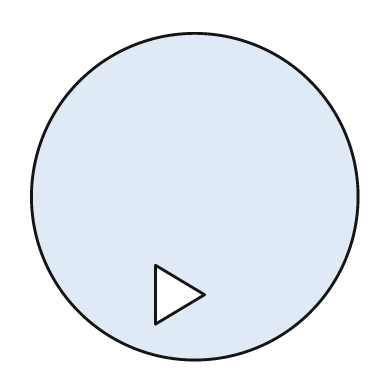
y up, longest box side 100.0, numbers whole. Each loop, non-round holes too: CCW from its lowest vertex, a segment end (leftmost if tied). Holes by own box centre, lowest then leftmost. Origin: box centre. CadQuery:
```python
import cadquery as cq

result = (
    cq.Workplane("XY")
    .moveTo(0.0, 0.0)
    .circle(50.0)
    .moveTo(-12.0, -39.0)
    .lineTo(3.0, -30.0)
    .lineTo(-12.0, -21.0)
    .close()
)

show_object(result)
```